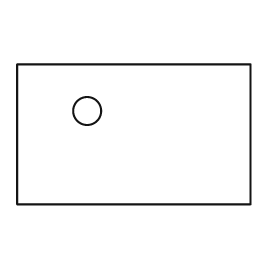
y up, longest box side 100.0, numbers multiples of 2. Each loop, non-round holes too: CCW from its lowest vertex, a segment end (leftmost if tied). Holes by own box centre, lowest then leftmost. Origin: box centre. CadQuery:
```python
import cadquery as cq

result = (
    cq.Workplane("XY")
    .moveTo(-50.0, -30.0)
    .lineTo(50.0, -30.0)
    .lineTo(50.0, 30.0)
    .lineTo(-50.0, 30.0)
    .close()
    .moveTo(-20.0, 10.0)
    .circle(6.0)
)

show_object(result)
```